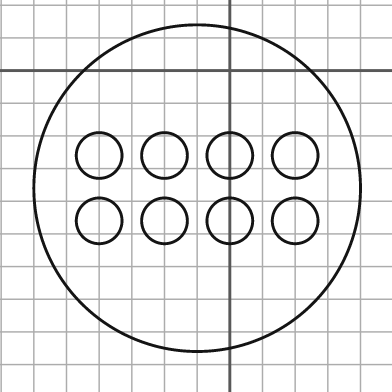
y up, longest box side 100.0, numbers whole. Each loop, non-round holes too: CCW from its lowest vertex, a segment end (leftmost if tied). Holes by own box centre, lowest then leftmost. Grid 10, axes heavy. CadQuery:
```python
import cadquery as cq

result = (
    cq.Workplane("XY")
    .moveTo(-10.0, -36.0)
    .circle(50.0)
    .moveTo(-40.0, -46.0)
    .circle(7.0)
    .moveTo(-20.0, -46.0)
    .circle(7.0)
    .moveTo(0.0, -46.0)
    .circle(7.0)
    .moveTo(20.0, -46.0)
    .circle(7.0)
    .moveTo(-40.0, -26.0)
    .circle(7.0)
    .moveTo(-20.0, -26.0)
    .circle(7.0)
    .moveTo(0.0, -26.0)
    .circle(7.0)
    .moveTo(20.0, -26.0)
    .circle(7.0)
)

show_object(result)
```